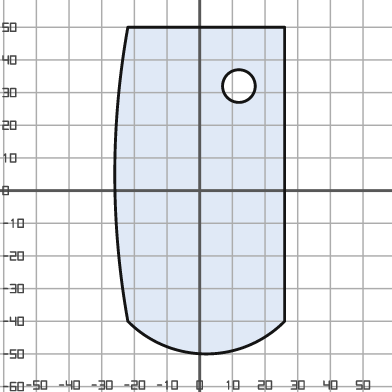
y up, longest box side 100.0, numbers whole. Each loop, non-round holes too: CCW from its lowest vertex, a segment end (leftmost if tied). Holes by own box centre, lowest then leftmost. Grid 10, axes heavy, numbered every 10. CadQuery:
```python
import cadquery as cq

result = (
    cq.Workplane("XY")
    .moveTo(-22.0, -40.0)
    .threePointArc((2.0, -50.0), (26.0, -40.0))
    .lineTo(26.0, 50.0)
    .lineTo(-22.0, 50.0)
    .threePointArc((-26.0, 5.0), (-22.0, -40.0))
    .close()
    .moveTo(12.0, 32.0)
    .circle(5.0)
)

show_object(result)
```